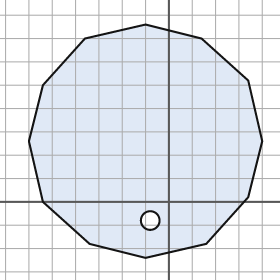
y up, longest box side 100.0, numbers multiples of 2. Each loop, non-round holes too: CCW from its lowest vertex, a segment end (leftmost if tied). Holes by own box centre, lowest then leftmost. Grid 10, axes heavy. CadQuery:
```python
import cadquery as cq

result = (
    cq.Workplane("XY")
    .moveTo(-10.0, -24.0)
    .lineTo(16.0, -18.0)
    .lineTo(34.0, 2.0)
    .lineTo(40.0, 26.0)
    .lineTo(34.0, 52.0)
    .lineTo(14.0, 70.0)
    .lineTo(-10.0, 76.0)
    .lineTo(-36.0, 70.0)
    .lineTo(-54.0, 50.0)
    .lineTo(-60.0, 26.0)
    .lineTo(-54.0, 0.0)
    .lineTo(-34.0, -18.0)
    .close()
    .moveTo(-8.0, -8.0)
    .circle(4.0)
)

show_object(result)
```